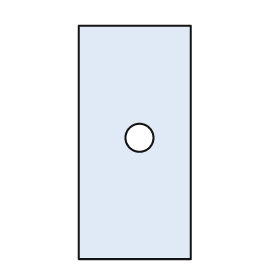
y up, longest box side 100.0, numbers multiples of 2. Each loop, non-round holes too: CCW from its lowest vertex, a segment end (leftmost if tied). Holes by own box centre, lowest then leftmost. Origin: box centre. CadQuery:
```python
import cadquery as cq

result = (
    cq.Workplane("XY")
    .moveTo(-24.0, -50.0)
    .lineTo(24.0, -50.0)
    .lineTo(24.0, 50.0)
    .lineTo(-24.0, 50.0)
    .close()
    .moveTo(2.0, 2.0)
    .circle(6.0)
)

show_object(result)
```